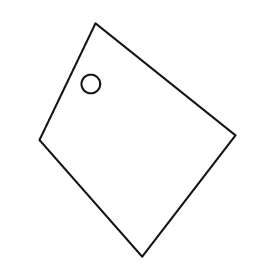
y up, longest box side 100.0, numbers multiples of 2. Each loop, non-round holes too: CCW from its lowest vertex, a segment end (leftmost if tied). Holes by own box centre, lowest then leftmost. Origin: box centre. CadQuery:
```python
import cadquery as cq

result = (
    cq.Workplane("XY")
    .moveTo(2.0, -50.0)
    .lineTo(42.0, 2.0)
    .lineTo(-18.0, 50.0)
    .lineTo(-42.0, 0.0)
    .close()
    .moveTo(-20.0, 24.0)
    .circle(4.0)
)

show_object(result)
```